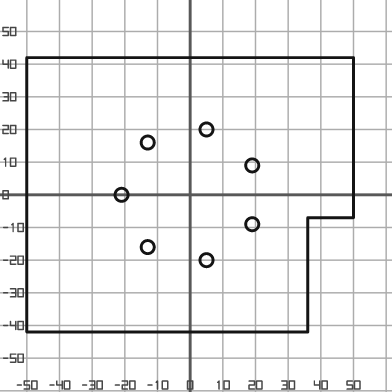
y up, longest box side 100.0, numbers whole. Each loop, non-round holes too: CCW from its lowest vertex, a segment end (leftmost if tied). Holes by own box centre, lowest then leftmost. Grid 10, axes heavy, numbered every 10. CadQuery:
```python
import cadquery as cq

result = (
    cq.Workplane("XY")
    .moveTo(-50.0, -42.0)
    .lineTo(36.0, -42.0)
    .lineTo(36.0, -7.0)
    .lineTo(50.0, -7.0)
    .lineTo(50.0, 42.0)
    .lineTo(-50.0, 42.0)
    .close()
    .moveTo(5.0, -20.0)
    .circle(2.0)
    .moveTo(-13.0, -16.0)
    .circle(2.0)
    .moveTo(19.0, -9.0)
    .circle(2.0)
    .moveTo(-21.0, 0.0)
    .circle(2.0)
    .moveTo(19.0, 9.0)
    .circle(2.0)
    .moveTo(-13.0, 16.0)
    .circle(2.0)
    .moveTo(5.0, 20.0)
    .circle(2.0)
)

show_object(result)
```